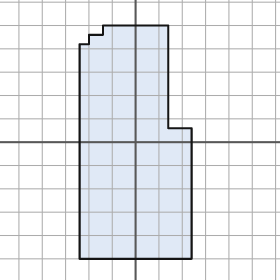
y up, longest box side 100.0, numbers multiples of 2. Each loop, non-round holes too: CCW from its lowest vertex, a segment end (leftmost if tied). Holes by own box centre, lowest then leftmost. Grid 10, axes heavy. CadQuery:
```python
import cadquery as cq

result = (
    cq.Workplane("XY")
    .moveTo(-24.0, -50.0)
    .lineTo(24.0, -50.0)
    .lineTo(24.0, 6.0)
    .lineTo(14.0, 6.0)
    .lineTo(14.0, 50.0)
    .lineTo(-14.0, 50.0)
    .lineTo(-14.0, 46.0)
    .lineTo(-20.0, 46.0)
    .lineTo(-20.0, 42.0)
    .lineTo(-24.0, 42.0)
    .close()
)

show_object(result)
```